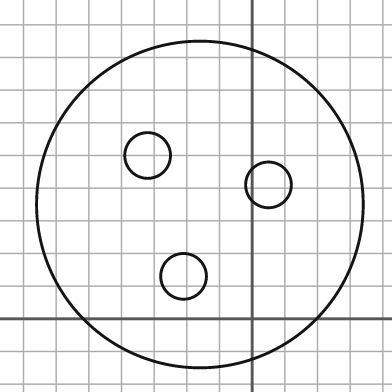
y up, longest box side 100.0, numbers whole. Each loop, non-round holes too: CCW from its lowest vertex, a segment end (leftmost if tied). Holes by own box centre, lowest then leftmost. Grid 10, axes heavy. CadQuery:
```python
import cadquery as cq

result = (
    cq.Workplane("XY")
    .moveTo(-16.0, 35.0)
    .circle(50.0)
    .moveTo(-21.0, 13.0)
    .circle(7.0)
    .moveTo(5.0, 41.0)
    .circle(7.0)
    .moveTo(-32.0, 50.0)
    .circle(7.0)
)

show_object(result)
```